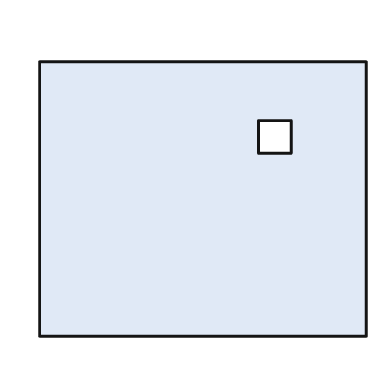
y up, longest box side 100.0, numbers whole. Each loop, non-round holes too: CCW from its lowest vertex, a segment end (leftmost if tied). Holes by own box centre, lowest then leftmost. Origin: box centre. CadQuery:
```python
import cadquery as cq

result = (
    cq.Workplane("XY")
    .moveTo(-50.0, -42.0)
    .lineTo(50.0, -42.0)
    .lineTo(50.0, 42.0)
    .lineTo(-50.0, 42.0)
    .close()
    .moveTo(17.0, 14.0)
    .lineTo(27.0, 14.0)
    .lineTo(27.0, 24.0)
    .lineTo(17.0, 24.0)
    .close()
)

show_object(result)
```